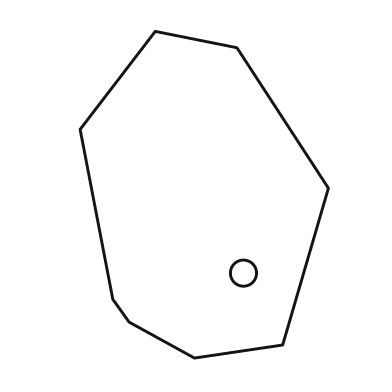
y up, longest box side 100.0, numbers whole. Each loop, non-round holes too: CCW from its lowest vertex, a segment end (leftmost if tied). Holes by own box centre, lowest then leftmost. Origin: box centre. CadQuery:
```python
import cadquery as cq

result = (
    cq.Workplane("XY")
    .moveTo(-3.0, -50.0)
    .lineTo(24.0, -46.0)
    .lineTo(38.0, 2.0)
    .lineTo(10.0, 45.0)
    .lineTo(-15.0, 50.0)
    .lineTo(-38.0, 20.0)
    .lineTo(-28.0, -32.0)
    .lineTo(-23.0, -39.0)
    .close()
    .moveTo(12.0, -24.0)
    .circle(4.0)
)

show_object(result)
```